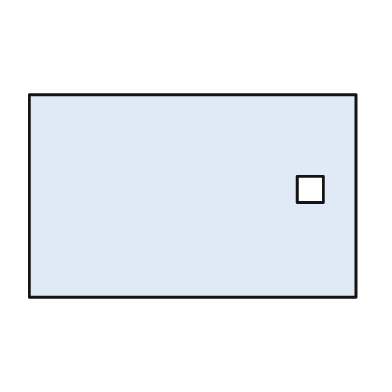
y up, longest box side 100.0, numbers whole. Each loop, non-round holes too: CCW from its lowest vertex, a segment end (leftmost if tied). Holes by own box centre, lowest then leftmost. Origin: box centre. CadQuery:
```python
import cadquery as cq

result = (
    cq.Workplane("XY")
    .moveTo(-50.0, -31.0)
    .lineTo(50.0, -31.0)
    .lineTo(50.0, 31.0)
    .lineTo(-50.0, 31.0)
    .close()
    .moveTo(32.0, -2.0)
    .lineTo(40.0, -2.0)
    .lineTo(40.0, 6.0)
    .lineTo(32.0, 6.0)
    .close()
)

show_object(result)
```